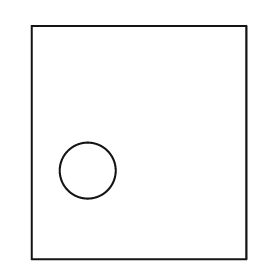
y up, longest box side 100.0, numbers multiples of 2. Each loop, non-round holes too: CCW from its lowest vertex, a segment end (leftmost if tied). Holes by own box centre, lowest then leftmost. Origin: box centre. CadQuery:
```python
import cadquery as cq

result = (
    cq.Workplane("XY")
    .moveTo(-46.0, -50.0)
    .lineTo(46.0, -50.0)
    .lineTo(46.0, 50.0)
    .lineTo(-46.0, 50.0)
    .close()
    .moveTo(-22.0, -12.0)
    .circle(12.0)
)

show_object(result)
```